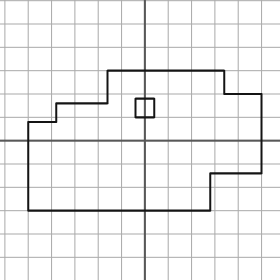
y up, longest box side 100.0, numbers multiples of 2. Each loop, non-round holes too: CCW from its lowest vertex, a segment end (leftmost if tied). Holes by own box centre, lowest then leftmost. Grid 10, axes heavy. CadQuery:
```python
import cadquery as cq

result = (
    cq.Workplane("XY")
    .moveTo(-50.0, -30.0)
    .lineTo(28.0, -30.0)
    .lineTo(28.0, -14.0)
    .lineTo(50.0, -14.0)
    .lineTo(50.0, 20.0)
    .lineTo(34.0, 20.0)
    .lineTo(34.0, 30.0)
    .lineTo(-16.0, 30.0)
    .lineTo(-16.0, 16.0)
    .lineTo(-38.0, 16.0)
    .lineTo(-38.0, 8.0)
    .lineTo(-50.0, 8.0)
    .close()
    .moveTo(-4.0, 10.0)
    .lineTo(4.0, 10.0)
    .lineTo(4.0, 18.0)
    .lineTo(-4.0, 18.0)
    .close()
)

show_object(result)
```